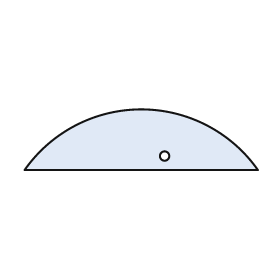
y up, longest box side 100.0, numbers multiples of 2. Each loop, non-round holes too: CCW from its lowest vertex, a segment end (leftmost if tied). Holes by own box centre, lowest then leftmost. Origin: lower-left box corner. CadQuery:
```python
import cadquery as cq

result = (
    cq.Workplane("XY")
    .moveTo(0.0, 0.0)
    .lineTo(100.0, 0.0)
    .threePointArc((50.0, 26.0), (0.0, 0.0))
    .close()
    .moveTo(60.0, 6.0)
    .circle(2.0)
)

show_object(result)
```